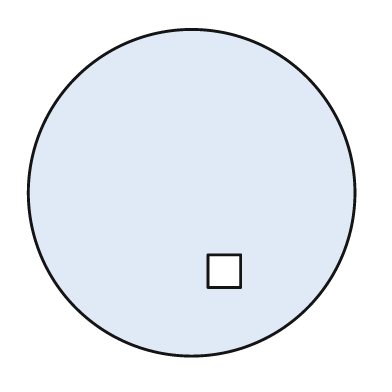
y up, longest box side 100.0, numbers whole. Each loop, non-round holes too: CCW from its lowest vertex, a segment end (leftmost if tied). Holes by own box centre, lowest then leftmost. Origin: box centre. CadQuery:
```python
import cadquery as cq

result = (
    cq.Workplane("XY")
    .moveTo(0.0, 0.0)
    .circle(50.0)
    .moveTo(5.0, -29.0)
    .lineTo(15.0, -29.0)
    .lineTo(15.0, -19.0)
    .lineTo(5.0, -19.0)
    .close()
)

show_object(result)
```